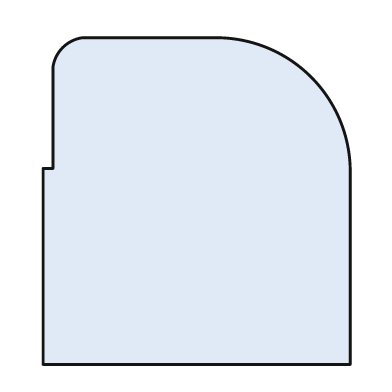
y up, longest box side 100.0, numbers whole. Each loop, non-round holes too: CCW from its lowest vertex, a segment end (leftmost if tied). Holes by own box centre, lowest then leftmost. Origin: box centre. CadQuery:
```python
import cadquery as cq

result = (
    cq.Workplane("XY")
    .moveTo(-47.0, -50.0)
    .lineTo(47.0, -50.0)
    .lineTo(47.0, 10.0)
    .threePointArc((35.0, 38.0), (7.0, 50.0))
    .lineTo(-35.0, 50.0)
    .threePointArc((-41.0, 47.0), (-44.0, 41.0))
    .lineTo(-44.0, 10.0)
    .lineTo(-47.0, 10.0)
    .close()
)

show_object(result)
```